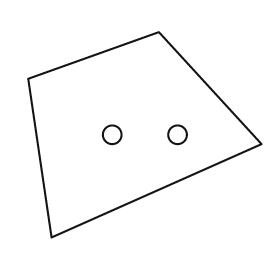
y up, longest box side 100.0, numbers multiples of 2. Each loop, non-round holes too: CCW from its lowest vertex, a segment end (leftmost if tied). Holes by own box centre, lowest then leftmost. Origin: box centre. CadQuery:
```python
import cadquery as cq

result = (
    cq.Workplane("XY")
    .moveTo(-40.0, -44.0)
    .lineTo(50.0, -4.0)
    .lineTo(6.0, 44.0)
    .lineTo(-50.0, 24.0)
    .close()
    .moveTo(-14.0, 0.0)
    .circle(4.0)
    .moveTo(14.0, 0.0)
    .circle(4.0)
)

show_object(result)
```